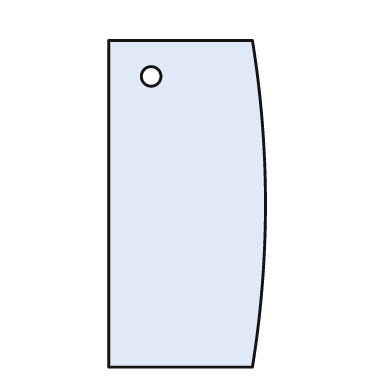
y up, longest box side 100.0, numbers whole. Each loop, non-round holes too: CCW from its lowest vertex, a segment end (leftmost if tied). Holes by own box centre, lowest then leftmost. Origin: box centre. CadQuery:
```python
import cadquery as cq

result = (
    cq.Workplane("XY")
    .moveTo(-24.0, -50.0)
    .lineTo(20.0, -50.0)
    .threePointArc((24.0, 0.0), (20.0, 50.0))
    .lineTo(-24.0, 50.0)
    .close()
    .moveTo(-11.0, 39.0)
    .circle(3.0)
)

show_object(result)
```